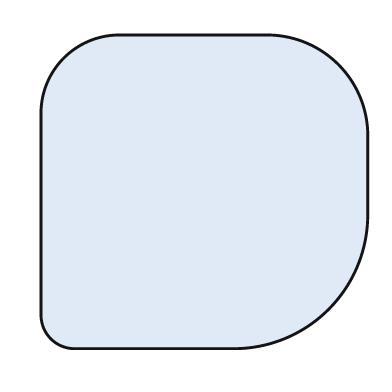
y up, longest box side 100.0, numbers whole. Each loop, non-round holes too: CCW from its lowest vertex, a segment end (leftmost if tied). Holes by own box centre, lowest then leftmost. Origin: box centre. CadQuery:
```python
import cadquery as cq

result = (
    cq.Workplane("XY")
    .moveTo(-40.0, -48.0)
    .lineTo(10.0, -48.0)
    .threePointArc((38.0, -36.0), (50.0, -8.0))
    .lineTo(50.0, 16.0)
    .threePointArc((41.0, 39.0), (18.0, 48.0))
    .lineTo(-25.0, 48.0)
    .threePointArc((-43.0, 41.0), (-50.0, 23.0))
    .lineTo(-50.0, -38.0)
    .threePointArc((-47.0, -45.0), (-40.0, -48.0))
    .close()
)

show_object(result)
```